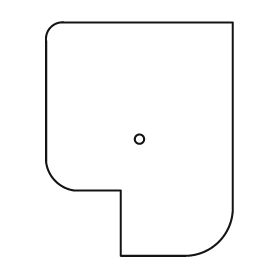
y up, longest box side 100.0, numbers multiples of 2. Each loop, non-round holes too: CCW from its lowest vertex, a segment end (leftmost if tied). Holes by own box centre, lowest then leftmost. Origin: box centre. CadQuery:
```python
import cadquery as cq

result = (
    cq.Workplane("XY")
    .moveTo(-8.0, -50.0)
    .lineTo(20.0, -50.0)
    .threePointArc((34.0, -44.0), (40.0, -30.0))
    .lineTo(40.0, 50.0)
    .lineTo(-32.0, 50.0)
    .threePointArc((-38.0, 48.0), (-40.0, 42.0))
    .lineTo(-40.0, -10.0)
    .threePointArc((-36.0, -18.0), (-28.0, -22.0))
    .lineTo(-8.0, -22.0)
    .close()
    .moveTo(0.0, 0.0)
    .circle(2.0)
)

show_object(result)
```